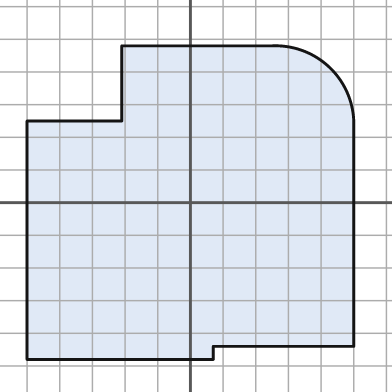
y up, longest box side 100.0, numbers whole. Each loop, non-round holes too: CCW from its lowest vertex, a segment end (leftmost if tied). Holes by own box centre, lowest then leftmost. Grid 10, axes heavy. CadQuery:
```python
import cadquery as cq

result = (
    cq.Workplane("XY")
    .moveTo(-50.0, -48.0)
    .lineTo(7.0, -48.0)
    .lineTo(7.0, -44.0)
    .lineTo(50.0, -44.0)
    .lineTo(50.0, 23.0)
    .threePointArc((43.0, 41.0), (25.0, 48.0))
    .lineTo(-21.0, 48.0)
    .lineTo(-21.0, 25.0)
    .lineTo(-50.0, 25.0)
    .close()
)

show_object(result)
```